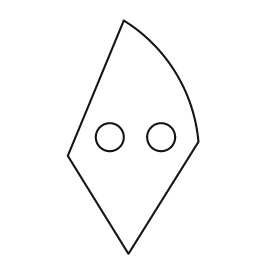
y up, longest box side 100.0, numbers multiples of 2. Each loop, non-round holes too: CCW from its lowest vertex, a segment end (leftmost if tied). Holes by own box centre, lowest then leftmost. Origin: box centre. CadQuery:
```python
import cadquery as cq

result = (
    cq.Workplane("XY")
    .moveTo(-2.0, -50.0)
    .lineTo(28.0, -2.0)
    .threePointArc((18.0, 28.0), (-4.0, 50.0))
    .lineTo(-28.0, -8.0)
    .close()
    .moveTo(-10.0, 0.0)
    .circle(6.0)
    .moveTo(12.0, 0.0)
    .circle(6.0)
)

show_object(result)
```